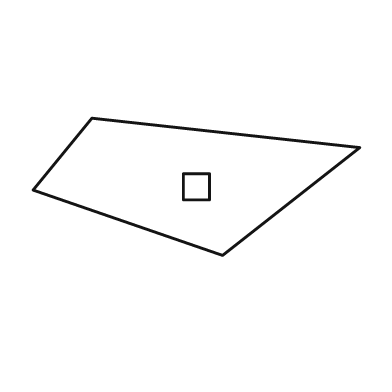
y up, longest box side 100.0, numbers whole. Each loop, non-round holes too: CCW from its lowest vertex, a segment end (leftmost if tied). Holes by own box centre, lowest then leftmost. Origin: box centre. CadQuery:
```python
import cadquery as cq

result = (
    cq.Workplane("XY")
    .moveTo(8.0, -21.0)
    .lineTo(50.0, 12.0)
    .lineTo(-32.0, 21.0)
    .lineTo(-50.0, -1.0)
    .close()
    .moveTo(-4.0, -4.0)
    .lineTo(4.0, -4.0)
    .lineTo(4.0, 4.0)
    .lineTo(-4.0, 4.0)
    .close()
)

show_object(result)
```